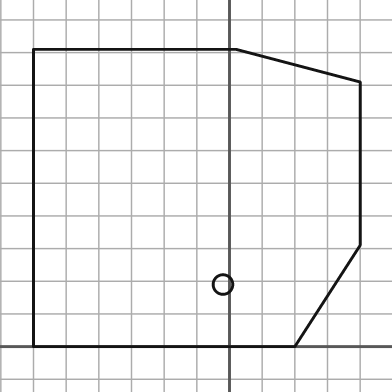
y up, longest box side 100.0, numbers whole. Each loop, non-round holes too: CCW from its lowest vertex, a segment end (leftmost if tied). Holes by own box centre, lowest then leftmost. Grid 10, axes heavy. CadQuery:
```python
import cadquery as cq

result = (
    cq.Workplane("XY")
    .moveTo(-60.0, 0.0)
    .lineTo(20.0, 0.0)
    .lineTo(40.0, 31.0)
    .lineTo(40.0, 81.0)
    .lineTo(2.0, 91.0)
    .lineTo(-60.0, 91.0)
    .close()
    .moveTo(-2.0, 19.0)
    .circle(3.0)
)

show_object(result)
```